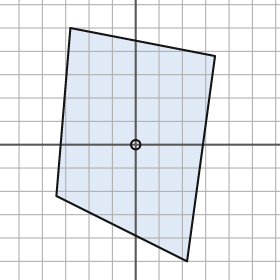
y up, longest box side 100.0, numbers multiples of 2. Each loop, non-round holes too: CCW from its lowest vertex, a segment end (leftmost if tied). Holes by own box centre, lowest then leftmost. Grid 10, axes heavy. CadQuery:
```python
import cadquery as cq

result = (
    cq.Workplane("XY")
    .moveTo(22.0, -50.0)
    .lineTo(34.0, 38.0)
    .lineTo(-28.0, 50.0)
    .lineTo(-34.0, -22.0)
    .close()
    .moveTo(0.0, 0.0)
    .circle(2.0)
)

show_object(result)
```